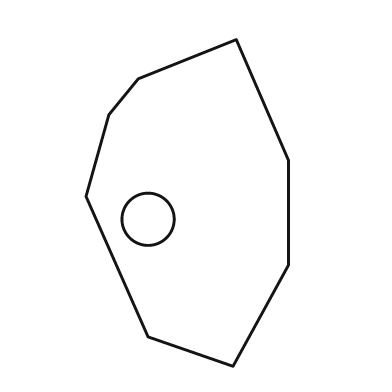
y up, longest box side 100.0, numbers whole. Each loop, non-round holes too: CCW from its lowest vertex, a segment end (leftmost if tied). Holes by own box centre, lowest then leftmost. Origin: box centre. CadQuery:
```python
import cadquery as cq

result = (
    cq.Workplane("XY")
    .moveTo(14.0, -50.0)
    .lineTo(31.0, -19.0)
    .lineTo(31.0, 13.0)
    .lineTo(15.0, 50.0)
    .lineTo(-15.0, 38.0)
    .lineTo(-24.0, 27.0)
    .lineTo(-31.0, 2.0)
    .lineTo(-12.0, -41.0)
    .close()
    .moveTo(-12.0, -5.0)
    .circle(8.0)
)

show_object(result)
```